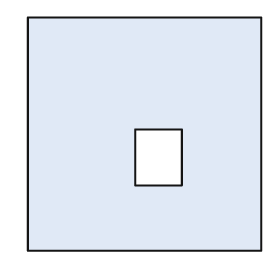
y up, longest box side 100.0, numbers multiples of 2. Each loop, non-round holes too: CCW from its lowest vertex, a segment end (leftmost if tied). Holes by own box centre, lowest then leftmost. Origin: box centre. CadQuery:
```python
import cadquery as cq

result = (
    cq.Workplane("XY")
    .moveTo(-50.0, -50.0)
    .lineTo(50.0, -50.0)
    .lineTo(50.0, 50.0)
    .lineTo(-50.0, 50.0)
    .close()
    .moveTo(-4.0, -22.0)
    .lineTo(16.0, -22.0)
    .lineTo(16.0, 2.0)
    .lineTo(-4.0, 2.0)
    .close()
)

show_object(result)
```